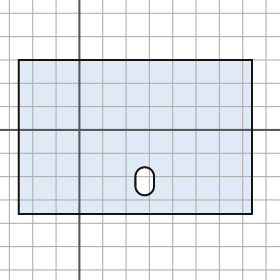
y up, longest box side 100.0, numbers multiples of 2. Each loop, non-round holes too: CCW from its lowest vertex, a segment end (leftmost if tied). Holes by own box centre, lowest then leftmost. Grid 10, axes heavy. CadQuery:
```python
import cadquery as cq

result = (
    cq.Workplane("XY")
    .moveTo(-26.0, -36.0)
    .lineTo(74.0, -36.0)
    .lineTo(74.0, 30.0)
    .lineTo(-26.0, 30.0)
    .close()
    .moveTo(24.0, -24.0)
    .threePointArc((28.0, -28.0), (32.0, -24.0))
    .lineTo(32.0, -20.0)
    .threePointArc((28.0, -16.0), (24.0, -20.0))
    .close()
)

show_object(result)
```